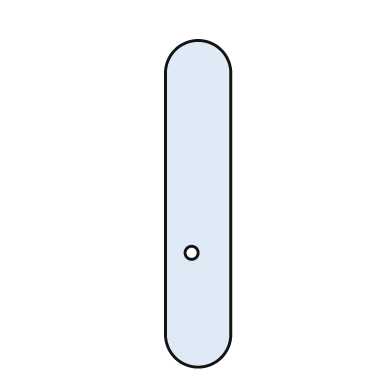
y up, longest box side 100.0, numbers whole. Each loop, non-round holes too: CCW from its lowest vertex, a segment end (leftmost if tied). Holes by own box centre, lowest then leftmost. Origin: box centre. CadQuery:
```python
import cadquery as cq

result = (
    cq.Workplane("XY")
    .moveTo(-10.0, -40.0)
    .threePointArc((0.0, -50.0), (10.0, -40.0))
    .lineTo(10.0, 40.0)
    .threePointArc((0.0, 50.0), (-10.0, 40.0))
    .close()
    .moveTo(-2.0, -15.0)
    .circle(2.0)
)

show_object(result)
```